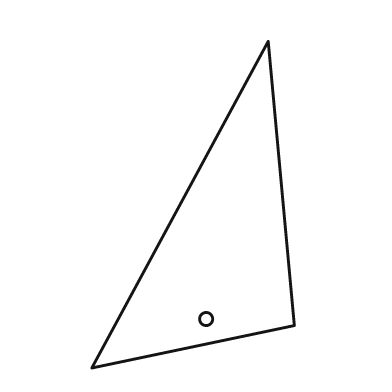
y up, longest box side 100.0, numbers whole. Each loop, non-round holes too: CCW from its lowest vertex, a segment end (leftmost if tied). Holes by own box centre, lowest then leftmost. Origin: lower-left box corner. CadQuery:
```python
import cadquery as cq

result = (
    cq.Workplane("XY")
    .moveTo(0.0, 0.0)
    .lineTo(62.0, 13.0)
    .lineTo(54.0, 100.0)
    .close()
    .moveTo(35.0, 15.0)
    .circle(2.0)
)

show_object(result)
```